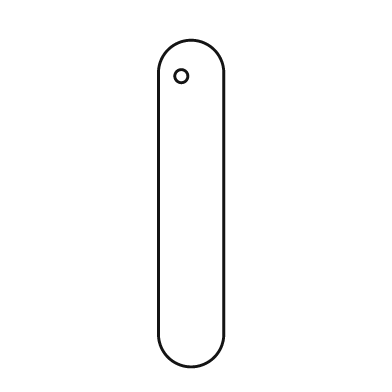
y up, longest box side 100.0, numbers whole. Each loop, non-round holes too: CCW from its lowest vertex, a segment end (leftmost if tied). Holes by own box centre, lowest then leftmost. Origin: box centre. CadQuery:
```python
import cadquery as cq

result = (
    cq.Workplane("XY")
    .moveTo(-10.0, -40.0)
    .threePointArc((0.0, -50.0), (10.0, -40.0))
    .lineTo(10.0, 40.0)
    .threePointArc((0.0, 50.0), (-10.0, 40.0))
    .close()
    .moveTo(-3.0, 39.0)
    .circle(2.0)
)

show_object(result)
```